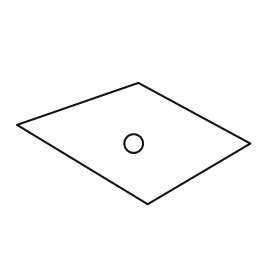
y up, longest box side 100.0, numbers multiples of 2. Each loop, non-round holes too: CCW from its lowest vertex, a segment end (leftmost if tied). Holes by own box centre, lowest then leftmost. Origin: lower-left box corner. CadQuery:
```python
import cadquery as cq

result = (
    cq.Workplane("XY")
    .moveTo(56.0, 0.0)
    .lineTo(100.0, 26.0)
    .lineTo(52.0, 52.0)
    .lineTo(0.0, 34.0)
    .close()
    .moveTo(50.0, 26.0)
    .circle(4.0)
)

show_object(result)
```